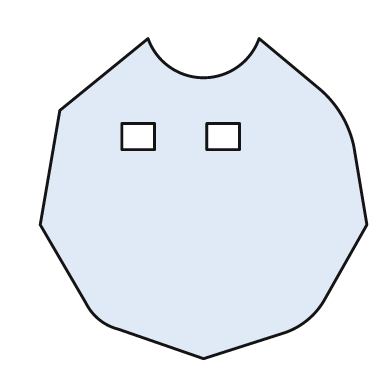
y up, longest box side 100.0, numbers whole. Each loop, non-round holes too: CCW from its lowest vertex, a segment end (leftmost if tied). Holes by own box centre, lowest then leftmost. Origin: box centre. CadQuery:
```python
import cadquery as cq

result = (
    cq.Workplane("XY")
    .moveTo(0.0, -49.0)
    .lineTo(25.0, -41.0)
    .threePointArc((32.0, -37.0), (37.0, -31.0))
    .lineTo(50.0, -8.0)
    .lineTo(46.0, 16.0)
    .threePointArc((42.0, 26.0), (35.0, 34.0))
    .lineTo(17.0, 49.0)
    .threePointArc((0.0, 37.0), (-17.0, 49.0))
    .lineTo(-44.0, 27.0)
    .lineTo(-50.0, -8.0)
    .lineTo(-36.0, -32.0)
    .threePointArc((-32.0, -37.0), (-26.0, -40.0))
    .close()
    .moveTo(-25.0, 15.0)
    .lineTo(-15.0, 15.0)
    .lineTo(-15.0, 23.0)
    .lineTo(-25.0, 23.0)
    .close()
    .moveTo(1.0, 15.0)
    .lineTo(11.0, 15.0)
    .lineTo(11.0, 23.0)
    .lineTo(1.0, 23.0)
    .close()
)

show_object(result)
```